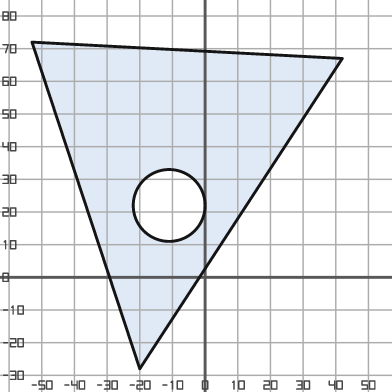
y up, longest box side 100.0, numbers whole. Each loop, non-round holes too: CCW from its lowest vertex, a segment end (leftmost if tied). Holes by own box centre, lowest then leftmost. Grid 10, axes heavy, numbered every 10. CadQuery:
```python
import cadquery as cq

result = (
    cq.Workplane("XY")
    .moveTo(-20.0, -28.0)
    .lineTo(42.0, 67.0)
    .lineTo(-53.0, 72.0)
    .close()
    .moveTo(-11.0, 22.0)
    .circle(11.0)
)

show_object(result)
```